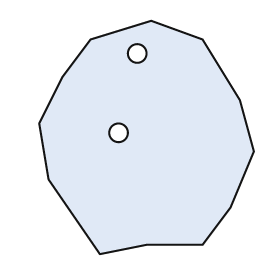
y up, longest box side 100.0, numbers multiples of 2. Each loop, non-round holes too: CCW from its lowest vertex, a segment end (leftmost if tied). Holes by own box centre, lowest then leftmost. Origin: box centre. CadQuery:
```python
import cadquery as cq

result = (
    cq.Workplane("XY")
    .moveTo(-20.0, -50.0)
    .lineTo(0.0, -46.0)
    .lineTo(24.0, -46.0)
    .lineTo(36.0, -30.0)
    .lineTo(46.0, -6.0)
    .lineTo(40.0, 16.0)
    .lineTo(24.0, 42.0)
    .lineTo(2.0, 50.0)
    .lineTo(-24.0, 42.0)
    .lineTo(-36.0, 26.0)
    .lineTo(-46.0, 6.0)
    .lineTo(-42.0, -18.0)
    .close()
    .moveTo(-12.0, 2.0)
    .circle(4.0)
    .moveTo(-4.0, 36.0)
    .circle(4.0)
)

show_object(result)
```